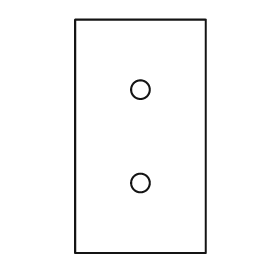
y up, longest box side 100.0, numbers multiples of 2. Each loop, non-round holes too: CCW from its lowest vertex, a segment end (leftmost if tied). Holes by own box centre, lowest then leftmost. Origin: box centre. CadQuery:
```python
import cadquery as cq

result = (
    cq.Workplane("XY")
    .moveTo(-28.0, -50.0)
    .lineTo(28.0, -50.0)
    .lineTo(28.0, 50.0)
    .lineTo(-28.0, 50.0)
    .close()
    .moveTo(0.0, -20.0)
    .circle(4.0)
    .moveTo(0.0, 20.0)
    .circle(4.0)
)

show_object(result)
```